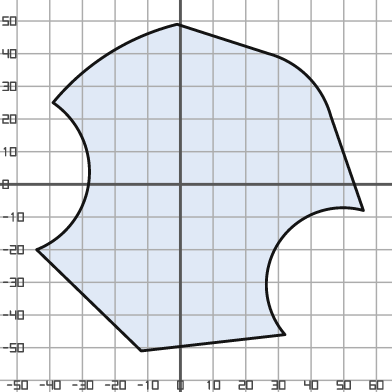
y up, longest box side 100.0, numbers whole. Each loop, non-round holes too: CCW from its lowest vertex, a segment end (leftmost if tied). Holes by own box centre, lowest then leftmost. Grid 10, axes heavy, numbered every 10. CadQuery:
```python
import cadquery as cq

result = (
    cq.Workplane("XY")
    .moveTo(-12.0, -51.0)
    .lineTo(32.0, -46.0)
    .threePointArc((30.0, -18.0), (56.0, -8.0))
    .lineTo(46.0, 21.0)
    .threePointArc((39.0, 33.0), (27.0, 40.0))
    .lineTo(-1.0, 49.0)
    .threePointArc((-22.0, 40.0), (-39.0, 25.0))
    .threePointArc((-28.0, 1.0), (-44.0, -20.0))
    .close()
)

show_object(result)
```